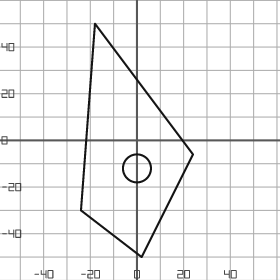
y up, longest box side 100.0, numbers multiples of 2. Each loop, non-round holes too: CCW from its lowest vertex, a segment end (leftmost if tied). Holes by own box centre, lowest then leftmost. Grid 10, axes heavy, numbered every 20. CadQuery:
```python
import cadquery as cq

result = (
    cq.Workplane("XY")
    .moveTo(2.0, -50.0)
    .lineTo(24.0, -6.0)
    .lineTo(-18.0, 50.0)
    .lineTo(-24.0, -30.0)
    .close()
    .moveTo(0.0, -12.0)
    .circle(6.0)
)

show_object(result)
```